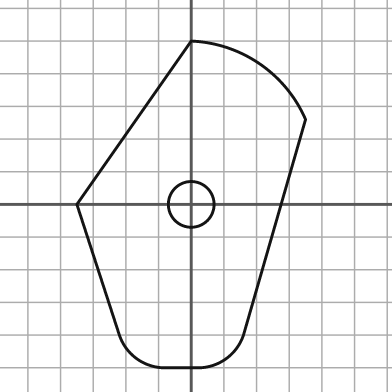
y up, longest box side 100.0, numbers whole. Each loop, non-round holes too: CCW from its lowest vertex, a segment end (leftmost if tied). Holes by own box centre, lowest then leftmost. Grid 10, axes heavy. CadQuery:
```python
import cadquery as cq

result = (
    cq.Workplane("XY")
    .moveTo(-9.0, -50.0)
    .lineTo(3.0, -50.0)
    .threePointArc((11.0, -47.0), (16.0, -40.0))
    .lineTo(35.0, 26.0)
    .threePointArc((21.0, 43.0), (0.0, 50.0))
    .lineTo(-35.0, 0.0)
    .lineTo(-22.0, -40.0)
    .threePointArc((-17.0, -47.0), (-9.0, -50.0))
    .close()
    .moveTo(0.0, 0.0)
    .circle(7.0)
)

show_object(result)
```